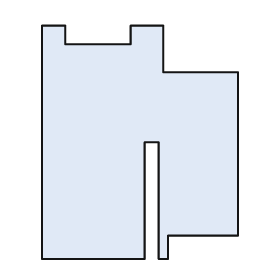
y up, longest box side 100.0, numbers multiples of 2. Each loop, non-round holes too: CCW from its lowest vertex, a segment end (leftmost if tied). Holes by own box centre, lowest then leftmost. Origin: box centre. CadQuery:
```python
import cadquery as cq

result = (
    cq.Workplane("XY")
    .moveTo(-42.0, -50.0)
    .lineTo(2.0, -50.0)
    .lineTo(2.0, 0.0)
    .lineTo(8.0, 0.0)
    .lineTo(8.0, -50.0)
    .lineTo(12.0, -50.0)
    .lineTo(12.0, -40.0)
    .lineTo(42.0, -40.0)
    .lineTo(42.0, 30.0)
    .lineTo(10.0, 30.0)
    .lineTo(10.0, 50.0)
    .lineTo(-4.0, 50.0)
    .lineTo(-4.0, 42.0)
    .lineTo(-32.0, 42.0)
    .lineTo(-32.0, 50.0)
    .lineTo(-42.0, 50.0)
    .close()
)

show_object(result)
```